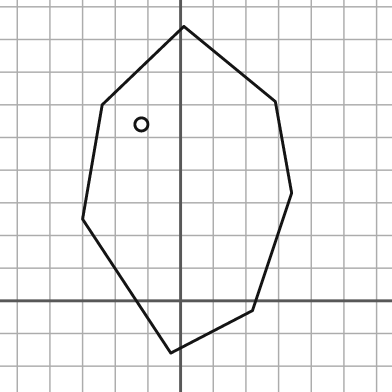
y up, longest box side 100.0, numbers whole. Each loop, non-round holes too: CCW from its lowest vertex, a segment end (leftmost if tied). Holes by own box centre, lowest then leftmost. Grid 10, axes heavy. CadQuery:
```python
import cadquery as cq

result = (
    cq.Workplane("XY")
    .moveTo(-3.0, -16.0)
    .lineTo(22.0, -3.0)
    .lineTo(34.0, 33.0)
    .lineTo(29.0, 61.0)
    .lineTo(1.0, 84.0)
    .lineTo(-24.0, 60.0)
    .lineTo(-30.0, 25.0)
    .close()
    .moveTo(-12.0, 54.0)
    .circle(2.0)
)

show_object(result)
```